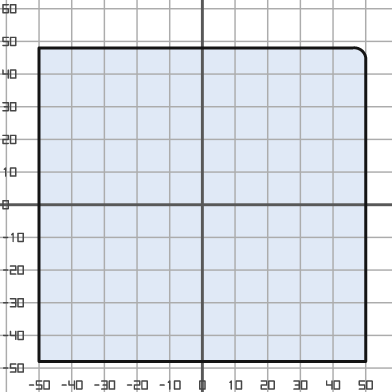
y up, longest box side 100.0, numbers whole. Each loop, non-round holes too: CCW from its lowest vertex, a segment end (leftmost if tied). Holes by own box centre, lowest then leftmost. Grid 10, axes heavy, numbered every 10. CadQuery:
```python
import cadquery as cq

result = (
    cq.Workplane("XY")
    .moveTo(-50.0, -48.0)
    .lineTo(50.0, -48.0)
    .lineTo(50.0, 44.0)
    .threePointArc((49.0, 47.0), (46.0, 48.0))
    .lineTo(-50.0, 48.0)
    .close()
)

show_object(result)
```